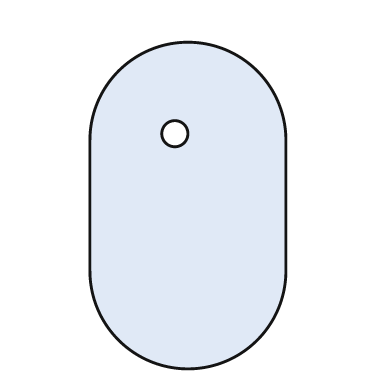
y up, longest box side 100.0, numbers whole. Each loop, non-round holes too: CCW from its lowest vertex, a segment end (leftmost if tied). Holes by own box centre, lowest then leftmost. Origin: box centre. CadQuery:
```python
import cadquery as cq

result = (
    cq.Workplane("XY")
    .moveTo(-30.0, -20.0)
    .threePointArc((0.0, -50.0), (30.0, -20.0))
    .lineTo(30.0, 20.0)
    .threePointArc((0.0, 50.0), (-30.0, 20.0))
    .close()
    .moveTo(-4.0, 22.0)
    .circle(4.0)
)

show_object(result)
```